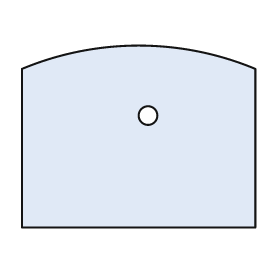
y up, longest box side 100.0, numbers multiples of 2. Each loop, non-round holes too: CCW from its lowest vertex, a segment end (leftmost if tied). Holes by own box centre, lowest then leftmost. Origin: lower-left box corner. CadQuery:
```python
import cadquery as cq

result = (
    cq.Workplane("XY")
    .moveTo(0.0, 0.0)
    .lineTo(100.0, 0.0)
    .lineTo(100.0, 68.0)
    .threePointArc((50.0, 78.0), (0.0, 68.0))
    .close()
    .moveTo(54.0, 48.0)
    .circle(4.0)
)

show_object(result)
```